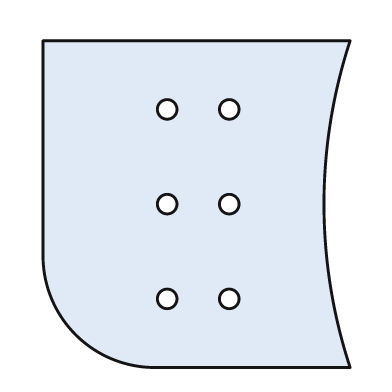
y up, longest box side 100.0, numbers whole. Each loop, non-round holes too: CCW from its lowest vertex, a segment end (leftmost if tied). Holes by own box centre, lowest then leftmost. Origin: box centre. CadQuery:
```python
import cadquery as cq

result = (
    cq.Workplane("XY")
    .moveTo(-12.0, -50.0)
    .lineTo(47.0, -50.0)
    .threePointArc((39.0, 0.0), (47.0, 50.0))
    .lineTo(-47.0, 50.0)
    .lineTo(-47.0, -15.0)
    .threePointArc((-37.0, -40.0), (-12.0, -50.0))
    .close()
    .moveTo(-9.0, -29.0)
    .circle(3.0)
    .moveTo(10.0, -29.0)
    .circle(3.0)
    .moveTo(-9.0, 0.0)
    .circle(3.0)
    .moveTo(10.0, 0.0)
    .circle(3.0)
    .moveTo(-9.0, 29.0)
    .circle(3.0)
    .moveTo(10.0, 29.0)
    .circle(3.0)
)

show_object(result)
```